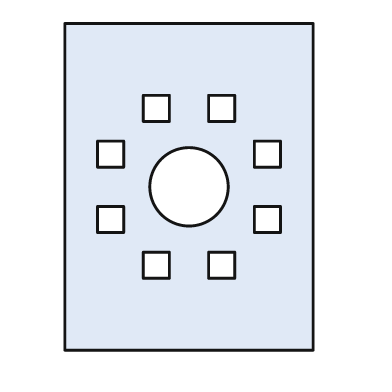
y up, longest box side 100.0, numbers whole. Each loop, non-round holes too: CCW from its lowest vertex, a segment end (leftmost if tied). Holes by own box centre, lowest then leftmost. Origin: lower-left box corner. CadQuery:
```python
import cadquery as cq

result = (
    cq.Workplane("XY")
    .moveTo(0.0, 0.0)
    .lineTo(76.0, 0.0)
    .lineTo(76.0, 100.0)
    .lineTo(0.0, 100.0)
    .close()
    .moveTo(24.0, 22.0)
    .lineTo(32.0, 22.0)
    .lineTo(32.0, 30.0)
    .lineTo(24.0, 30.0)
    .close()
    .moveTo(44.0, 22.0)
    .lineTo(52.0, 22.0)
    .lineTo(52.0, 30.0)
    .lineTo(44.0, 30.0)
    .close()
    .moveTo(10.0, 36.0)
    .lineTo(18.0, 36.0)
    .lineTo(18.0, 44.0)
    .lineTo(10.0, 44.0)
    .close()
    .moveTo(58.0, 36.0)
    .lineTo(66.0, 36.0)
    .lineTo(66.0, 44.0)
    .lineTo(58.0, 44.0)
    .close()
    .moveTo(38.0, 50.0)
    .circle(12.0)
    .moveTo(10.0, 56.0)
    .lineTo(18.0, 56.0)
    .lineTo(18.0, 64.0)
    .lineTo(10.0, 64.0)
    .close()
    .moveTo(58.0, 56.0)
    .lineTo(66.0, 56.0)
    .lineTo(66.0, 64.0)
    .lineTo(58.0, 64.0)
    .close()
    .moveTo(24.0, 70.0)
    .lineTo(32.0, 70.0)
    .lineTo(32.0, 78.0)
    .lineTo(24.0, 78.0)
    .close()
    .moveTo(44.0, 70.0)
    .lineTo(52.0, 70.0)
    .lineTo(52.0, 78.0)
    .lineTo(44.0, 78.0)
    .close()
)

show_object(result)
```